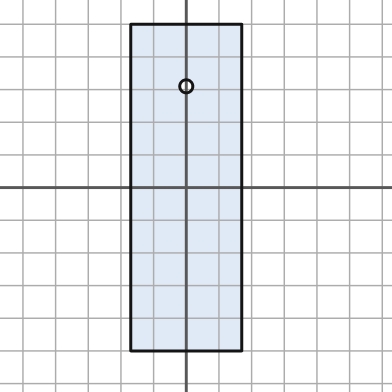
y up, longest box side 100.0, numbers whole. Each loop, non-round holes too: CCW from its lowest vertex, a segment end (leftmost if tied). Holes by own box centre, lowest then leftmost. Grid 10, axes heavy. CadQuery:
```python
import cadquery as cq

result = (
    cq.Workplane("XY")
    .moveTo(-17.0, -50.0)
    .lineTo(17.0, -50.0)
    .lineTo(17.0, 50.0)
    .lineTo(-17.0, 50.0)
    .close()
    .moveTo(0.0, 31.0)
    .circle(2.0)
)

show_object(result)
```